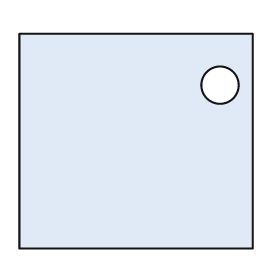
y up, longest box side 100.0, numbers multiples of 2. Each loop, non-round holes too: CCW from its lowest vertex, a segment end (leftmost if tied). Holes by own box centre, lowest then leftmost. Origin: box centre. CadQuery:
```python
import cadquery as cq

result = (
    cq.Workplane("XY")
    .moveTo(-50.0, -46.0)
    .lineTo(50.0, -46.0)
    .lineTo(50.0, 46.0)
    .lineTo(-50.0, 46.0)
    .close()
    .moveTo(36.0, 24.0)
    .circle(8.0)
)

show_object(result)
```